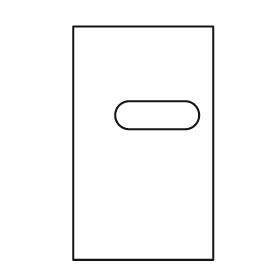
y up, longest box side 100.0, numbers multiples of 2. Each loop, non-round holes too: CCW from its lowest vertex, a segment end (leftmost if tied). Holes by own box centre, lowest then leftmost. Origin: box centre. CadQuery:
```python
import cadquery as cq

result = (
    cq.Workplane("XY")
    .moveTo(-30.0, -50.0)
    .lineTo(30.0, -50.0)
    .lineTo(30.0, 50.0)
    .lineTo(-30.0, 50.0)
    .close()
    .moveTo(-6.0, 6.0)
    .lineTo(18.0, 6.0)
    .threePointArc((24.0, 12.0), (18.0, 18.0))
    .lineTo(-6.0, 18.0)
    .threePointArc((-12.0, 12.0), (-6.0, 6.0))
    .close()
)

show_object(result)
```